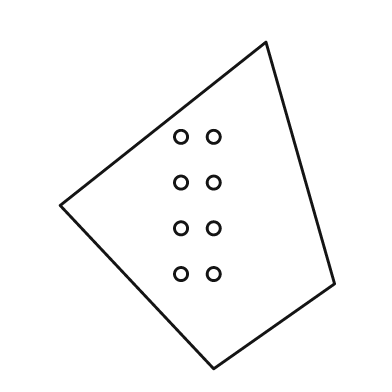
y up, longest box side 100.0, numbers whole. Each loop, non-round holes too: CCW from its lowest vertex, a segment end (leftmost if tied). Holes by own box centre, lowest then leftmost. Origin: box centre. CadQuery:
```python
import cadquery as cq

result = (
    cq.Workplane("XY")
    .moveTo(5.0, -50.0)
    .lineTo(42.0, -24.0)
    .lineTo(21.0, 50.0)
    .lineTo(-42.0, 0.0)
    .close()
    .moveTo(-5.0, -21.0)
    .circle(2.0)
    .moveTo(5.0, -21.0)
    .circle(2.0)
    .moveTo(-5.0, -7.0)
    .circle(2.0)
    .moveTo(5.0, -7.0)
    .circle(2.0)
    .moveTo(-5.0, 7.0)
    .circle(2.0)
    .moveTo(5.0, 7.0)
    .circle(2.0)
    .moveTo(-5.0, 21.0)
    .circle(2.0)
    .moveTo(5.0, 21.0)
    .circle(2.0)
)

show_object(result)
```